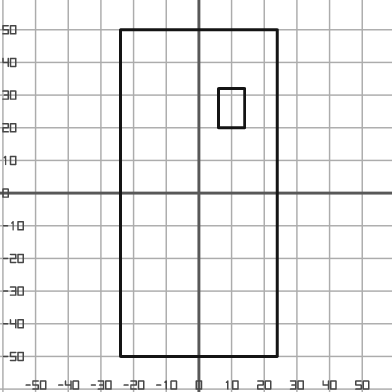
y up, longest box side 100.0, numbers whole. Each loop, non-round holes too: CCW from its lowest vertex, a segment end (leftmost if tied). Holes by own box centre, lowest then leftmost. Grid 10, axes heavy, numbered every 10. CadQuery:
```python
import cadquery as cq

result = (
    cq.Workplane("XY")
    .moveTo(-24.0, -50.0)
    .lineTo(24.0, -50.0)
    .lineTo(24.0, 50.0)
    .lineTo(-24.0, 50.0)
    .close()
    .moveTo(6.0, 20.0)
    .lineTo(14.0, 20.0)
    .lineTo(14.0, 32.0)
    .lineTo(6.0, 32.0)
    .close()
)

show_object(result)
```